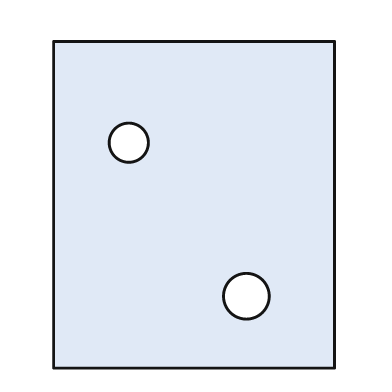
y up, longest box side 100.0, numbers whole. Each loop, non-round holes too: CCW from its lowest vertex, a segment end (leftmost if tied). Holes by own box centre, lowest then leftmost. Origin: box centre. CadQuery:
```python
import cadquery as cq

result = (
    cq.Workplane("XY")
    .moveTo(-43.0, -50.0)
    .lineTo(43.0, -50.0)
    .lineTo(43.0, 50.0)
    .lineTo(-43.0, 50.0)
    .close()
    .moveTo(16.0, -28.0)
    .circle(7.0)
    .moveTo(-20.0, 19.0)
    .circle(6.0)
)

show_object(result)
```